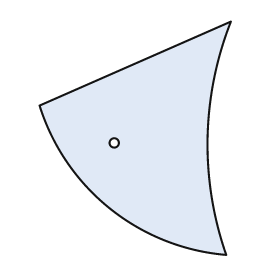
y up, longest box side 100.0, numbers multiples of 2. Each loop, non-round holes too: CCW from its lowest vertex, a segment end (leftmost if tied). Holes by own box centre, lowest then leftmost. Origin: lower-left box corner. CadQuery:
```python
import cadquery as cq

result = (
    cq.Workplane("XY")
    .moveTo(80.0, 0.0)
    .threePointArc((72.0, 50.0), (82.0, 100.0))
    .lineTo(0.0, 64.0)
    .threePointArc((30.0, 20.0), (80.0, 0.0))
    .close()
    .moveTo(32.0, 48.0)
    .circle(2.0)
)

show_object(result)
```